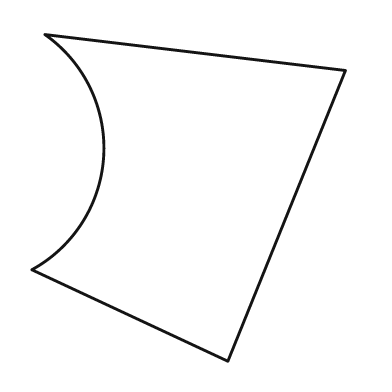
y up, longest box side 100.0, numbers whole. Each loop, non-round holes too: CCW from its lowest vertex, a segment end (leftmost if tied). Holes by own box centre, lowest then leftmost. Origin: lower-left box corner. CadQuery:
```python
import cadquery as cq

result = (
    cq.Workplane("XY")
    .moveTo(60.0, 0.0)
    .lineTo(96.0, 89.0)
    .lineTo(4.0, 100.0)
    .threePointArc((22.0, 63.0), (0.0, 28.0))
    .close()
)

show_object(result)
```